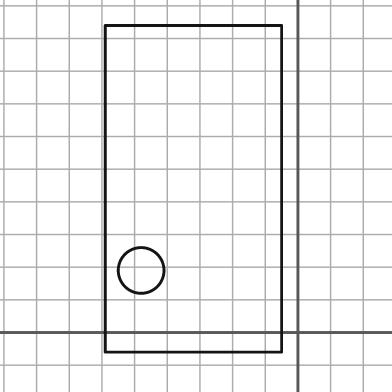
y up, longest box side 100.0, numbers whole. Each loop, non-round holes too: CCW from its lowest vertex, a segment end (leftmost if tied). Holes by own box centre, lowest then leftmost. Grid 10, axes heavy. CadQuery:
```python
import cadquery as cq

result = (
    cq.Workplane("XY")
    .moveTo(-59.0, -6.0)
    .lineTo(-5.0, -6.0)
    .lineTo(-5.0, 94.0)
    .lineTo(-59.0, 94.0)
    .close()
    .moveTo(-48.0, 19.0)
    .circle(7.0)
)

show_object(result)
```